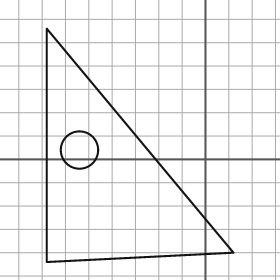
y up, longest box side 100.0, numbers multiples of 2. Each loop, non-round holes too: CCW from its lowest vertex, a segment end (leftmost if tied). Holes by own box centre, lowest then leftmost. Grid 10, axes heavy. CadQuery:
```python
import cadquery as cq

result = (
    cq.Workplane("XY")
    .moveTo(-68.0, -44.0)
    .lineTo(12.0, -40.0)
    .lineTo(-68.0, 56.0)
    .close()
    .moveTo(-54.0, 4.0)
    .circle(8.0)
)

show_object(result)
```